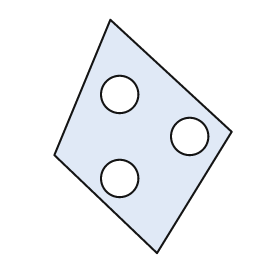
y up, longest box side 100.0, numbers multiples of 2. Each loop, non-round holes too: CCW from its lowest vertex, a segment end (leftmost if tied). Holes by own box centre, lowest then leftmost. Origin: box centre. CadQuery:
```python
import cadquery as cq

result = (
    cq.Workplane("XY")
    .moveTo(6.0, -50.0)
    .lineTo(38.0, 2.0)
    .lineTo(-14.0, 50.0)
    .lineTo(-38.0, -8.0)
    .close()
    .moveTo(-10.0, -18.0)
    .circle(8.0)
    .moveTo(20.0, 0.0)
    .circle(8.0)
    .moveTo(-10.0, 18.0)
    .circle(8.0)
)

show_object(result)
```